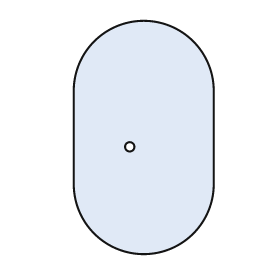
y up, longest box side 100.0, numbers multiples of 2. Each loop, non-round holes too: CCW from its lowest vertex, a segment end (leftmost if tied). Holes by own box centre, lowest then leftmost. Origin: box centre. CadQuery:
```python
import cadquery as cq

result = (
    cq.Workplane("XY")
    .moveTo(-30.0, -20.0)
    .threePointArc((0.0, -50.0), (30.0, -20.0))
    .lineTo(30.0, 20.0)
    .threePointArc((0.0, 50.0), (-30.0, 20.0))
    .close()
    .moveTo(-6.0, -4.0)
    .circle(2.0)
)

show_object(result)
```